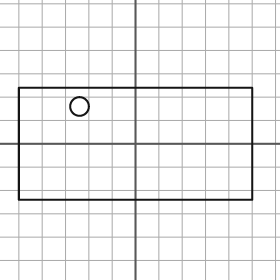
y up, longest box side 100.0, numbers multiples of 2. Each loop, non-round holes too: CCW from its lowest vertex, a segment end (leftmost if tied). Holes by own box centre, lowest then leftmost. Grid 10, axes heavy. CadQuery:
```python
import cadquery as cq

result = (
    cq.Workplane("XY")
    .moveTo(-50.0, -24.0)
    .lineTo(50.0, -24.0)
    .lineTo(50.0, 24.0)
    .lineTo(-50.0, 24.0)
    .close()
    .moveTo(-24.0, 16.0)
    .circle(4.0)
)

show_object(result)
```